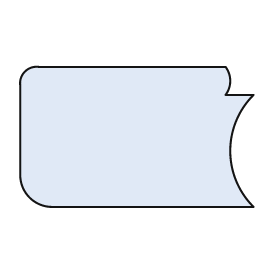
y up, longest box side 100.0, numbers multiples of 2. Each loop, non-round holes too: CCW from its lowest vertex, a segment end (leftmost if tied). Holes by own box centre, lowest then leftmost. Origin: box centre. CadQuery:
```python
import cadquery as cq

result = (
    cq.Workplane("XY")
    .moveTo(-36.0, -30.0)
    .lineTo(50.0, -30.0)
    .threePointArc((40.0, -6.0), (50.0, 18.0))
    .lineTo(38.0, 18.0)
    .threePointArc((40.0, 24.0), (38.0, 30.0))
    .lineTo(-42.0, 30.0)
    .threePointArc((-48.0, 28.0), (-50.0, 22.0))
    .lineTo(-50.0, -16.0)
    .threePointArc((-46.0, -26.0), (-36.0, -30.0))
    .close()
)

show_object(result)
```